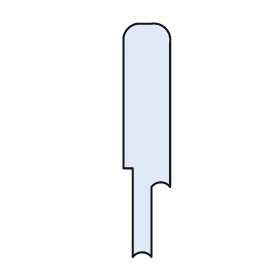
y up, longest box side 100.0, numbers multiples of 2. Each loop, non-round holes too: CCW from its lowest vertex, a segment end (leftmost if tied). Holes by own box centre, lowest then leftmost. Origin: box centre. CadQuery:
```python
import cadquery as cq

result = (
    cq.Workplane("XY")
    .moveTo(-6.0, -50.0)
    .threePointArc((-2.0, -48.0), (2.0, -50.0))
    .lineTo(2.0, -20.0)
    .threePointArc((6.0, -18.0), (10.0, -20.0))
    .lineTo(10.0, 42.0)
    .threePointArc((8.0, 48.0), (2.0, 50.0))
    .lineTo(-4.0, 50.0)
    .threePointArc((-8.0, 48.0), (-10.0, 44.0))
    .lineTo(-10.0, -12.0)
    .lineTo(-6.0, -12.0)
    .close()
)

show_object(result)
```